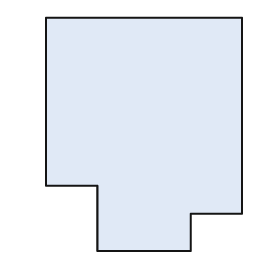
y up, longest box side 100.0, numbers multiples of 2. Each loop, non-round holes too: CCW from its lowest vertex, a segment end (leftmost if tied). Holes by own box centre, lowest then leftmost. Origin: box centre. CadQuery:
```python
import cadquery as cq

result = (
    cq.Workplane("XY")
    .moveTo(-20.0, -50.0)
    .lineTo(20.0, -50.0)
    .lineTo(20.0, -34.0)
    .lineTo(42.0, -34.0)
    .lineTo(42.0, 50.0)
    .lineTo(-42.0, 50.0)
    .lineTo(-42.0, -22.0)
    .lineTo(-20.0, -22.0)
    .close()
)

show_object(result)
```